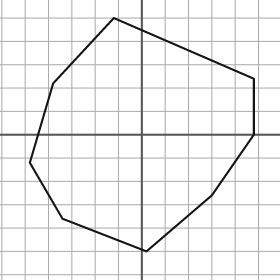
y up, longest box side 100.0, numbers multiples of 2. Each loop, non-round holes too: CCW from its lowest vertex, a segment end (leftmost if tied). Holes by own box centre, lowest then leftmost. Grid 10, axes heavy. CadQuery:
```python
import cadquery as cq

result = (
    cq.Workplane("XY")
    .moveTo(2.0, -50.0)
    .lineTo(30.0, -26.0)
    .lineTo(48.0, 0.0)
    .lineTo(48.0, 24.0)
    .lineTo(-12.0, 50.0)
    .lineTo(-38.0, 22.0)
    .lineTo(-48.0, -12.0)
    .lineTo(-34.0, -36.0)
    .close()
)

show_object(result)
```